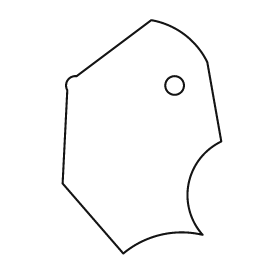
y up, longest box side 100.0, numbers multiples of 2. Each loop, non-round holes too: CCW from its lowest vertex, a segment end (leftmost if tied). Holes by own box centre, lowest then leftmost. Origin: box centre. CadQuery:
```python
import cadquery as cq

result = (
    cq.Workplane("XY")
    .moveTo(-8.0, -50.0)
    .threePointArc((8.0, -42.0), (26.0, -42.0))
    .threePointArc((20.0, -20.0), (34.0, -2.0))
    .lineTo(28.0, 32.0)
    .threePointArc((18.0, 44.0), (4.0, 50.0))
    .lineTo(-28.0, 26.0)
    .threePointArc((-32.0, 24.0), (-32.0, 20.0))
    .lineTo(-34.0, -20.0)
    .close()
    .moveTo(14.0, 22.0)
    .circle(4.0)
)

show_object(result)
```